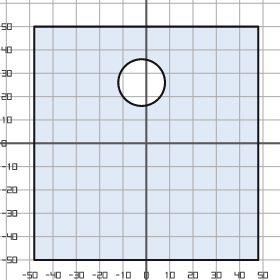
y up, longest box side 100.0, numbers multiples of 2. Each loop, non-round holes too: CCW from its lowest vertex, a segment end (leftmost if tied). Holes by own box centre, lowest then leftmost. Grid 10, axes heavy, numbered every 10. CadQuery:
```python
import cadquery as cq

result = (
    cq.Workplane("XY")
    .moveTo(-48.0, -50.0)
    .lineTo(48.0, -50.0)
    .lineTo(48.0, 50.0)
    .lineTo(-48.0, 50.0)
    .close()
    .moveTo(-2.0, 26.0)
    .circle(10.0)
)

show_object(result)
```